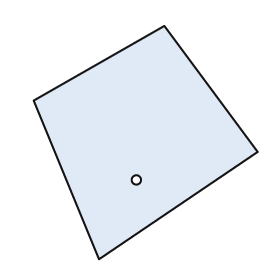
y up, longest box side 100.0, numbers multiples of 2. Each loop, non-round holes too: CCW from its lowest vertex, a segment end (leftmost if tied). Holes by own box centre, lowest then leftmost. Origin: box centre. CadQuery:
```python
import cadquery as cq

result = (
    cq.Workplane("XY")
    .moveTo(-20.0, -50.0)
    .lineTo(48.0, -4.0)
    .lineTo(8.0, 50.0)
    .lineTo(-48.0, 18.0)
    .close()
    .moveTo(-4.0, -16.0)
    .circle(2.0)
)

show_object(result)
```